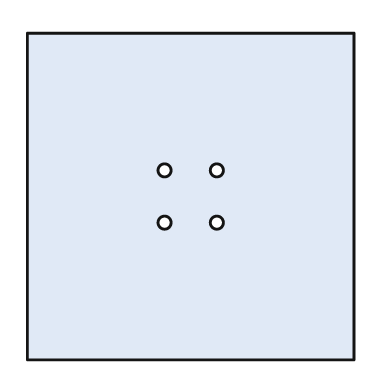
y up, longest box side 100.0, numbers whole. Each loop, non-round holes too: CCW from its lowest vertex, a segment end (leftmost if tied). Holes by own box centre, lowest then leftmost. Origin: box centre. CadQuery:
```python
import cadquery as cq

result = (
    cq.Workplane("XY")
    .moveTo(-50.0, -50.0)
    .lineTo(50.0, -50.0)
    .lineTo(50.0, 50.0)
    .lineTo(-50.0, 50.0)
    .close()
    .moveTo(-8.0, -8.0)
    .circle(2.0)
    .moveTo(8.0, -8.0)
    .circle(2.0)
    .moveTo(-8.0, 8.0)
    .circle(2.0)
    .moveTo(8.0, 8.0)
    .circle(2.0)
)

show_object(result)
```